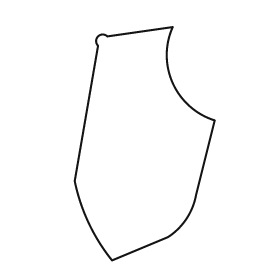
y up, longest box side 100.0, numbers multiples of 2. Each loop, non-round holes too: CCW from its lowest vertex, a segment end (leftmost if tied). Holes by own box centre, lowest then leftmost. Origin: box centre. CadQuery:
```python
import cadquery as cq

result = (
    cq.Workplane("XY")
    .moveTo(-14.0, -50.0)
    .lineTo(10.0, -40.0)
    .threePointArc((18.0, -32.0), (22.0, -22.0))
    .lineTo(30.0, 10.0)
    .threePointArc((12.0, 26.0), (12.0, 50.0))
    .lineTo(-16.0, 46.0)
    .threePointArc((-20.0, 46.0), (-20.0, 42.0))
    .lineTo(-30.0, -16.0)
    .threePointArc((-24.0, -34.0), (-14.0, -50.0))
    .close()
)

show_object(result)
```